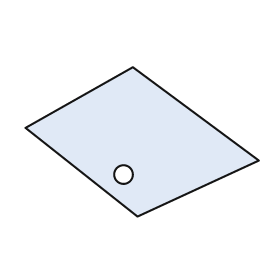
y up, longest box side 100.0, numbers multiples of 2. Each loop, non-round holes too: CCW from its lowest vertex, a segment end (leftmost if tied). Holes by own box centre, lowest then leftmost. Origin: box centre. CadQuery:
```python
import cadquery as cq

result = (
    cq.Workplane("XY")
    .moveTo(-2.0, -32.0)
    .lineTo(50.0, -8.0)
    .lineTo(-4.0, 32.0)
    .lineTo(-50.0, 6.0)
    .close()
    .moveTo(-8.0, -14.0)
    .circle(4.0)
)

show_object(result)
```